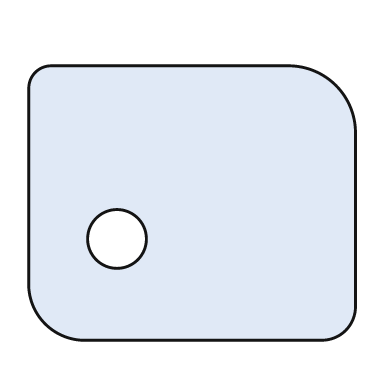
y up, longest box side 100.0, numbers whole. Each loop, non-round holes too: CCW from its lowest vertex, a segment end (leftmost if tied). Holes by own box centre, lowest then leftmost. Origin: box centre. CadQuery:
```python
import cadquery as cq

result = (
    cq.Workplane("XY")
    .moveTo(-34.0, -42.0)
    .lineTo(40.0, -42.0)
    .threePointArc((47.0, -39.0), (50.0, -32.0))
    .lineTo(50.0, 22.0)
    .threePointArc((44.0, 36.0), (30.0, 42.0))
    .lineTo(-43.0, 42.0)
    .threePointArc((-48.0, 40.0), (-50.0, 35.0))
    .lineTo(-50.0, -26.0)
    .threePointArc((-45.0, -37.0), (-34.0, -42.0))
    .close()
    .moveTo(-23.0, -11.0)
    .circle(9.0)
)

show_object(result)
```